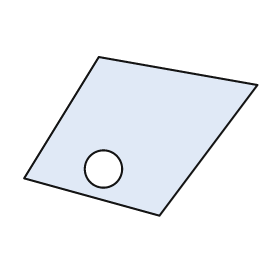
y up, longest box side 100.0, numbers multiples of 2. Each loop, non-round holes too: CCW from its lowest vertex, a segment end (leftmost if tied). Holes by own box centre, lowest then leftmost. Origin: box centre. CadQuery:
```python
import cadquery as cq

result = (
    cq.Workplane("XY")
    .moveTo(8.0, -34.0)
    .lineTo(50.0, 22.0)
    .lineTo(-18.0, 34.0)
    .lineTo(-50.0, -18.0)
    .close()
    .moveTo(-16.0, -14.0)
    .circle(8.0)
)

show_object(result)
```